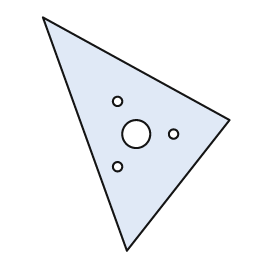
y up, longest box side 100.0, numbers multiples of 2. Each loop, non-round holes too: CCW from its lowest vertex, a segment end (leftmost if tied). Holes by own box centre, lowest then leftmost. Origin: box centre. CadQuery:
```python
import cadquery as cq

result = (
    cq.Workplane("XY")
    .moveTo(-4.0, -50.0)
    .lineTo(40.0, 6.0)
    .lineTo(-40.0, 50.0)
    .close()
    .moveTo(-8.0, -14.0)
    .circle(2.0)
    .moveTo(0.0, 0.0)
    .circle(6.0)
    .moveTo(16.0, 0.0)
    .circle(2.0)
    .moveTo(-8.0, 14.0)
    .circle(2.0)
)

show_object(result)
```